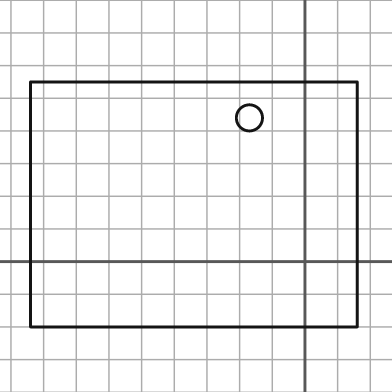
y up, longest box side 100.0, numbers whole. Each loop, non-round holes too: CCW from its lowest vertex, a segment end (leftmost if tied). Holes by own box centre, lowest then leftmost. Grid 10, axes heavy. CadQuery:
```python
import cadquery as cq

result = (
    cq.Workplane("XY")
    .moveTo(-84.0, -20.0)
    .lineTo(16.0, -20.0)
    .lineTo(16.0, 55.0)
    .lineTo(-84.0, 55.0)
    .close()
    .moveTo(-17.0, 44.0)
    .circle(4.0)
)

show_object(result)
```